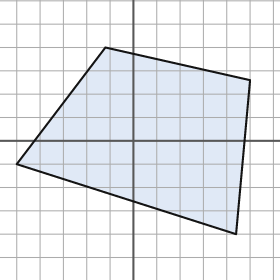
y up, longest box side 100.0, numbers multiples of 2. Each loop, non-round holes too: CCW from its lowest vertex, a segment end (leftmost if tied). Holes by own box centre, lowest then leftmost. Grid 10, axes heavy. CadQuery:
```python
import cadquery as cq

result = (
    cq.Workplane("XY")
    .moveTo(44.0, -40.0)
    .lineTo(50.0, 26.0)
    .lineTo(-12.0, 40.0)
    .lineTo(-50.0, -10.0)
    .close()
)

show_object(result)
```